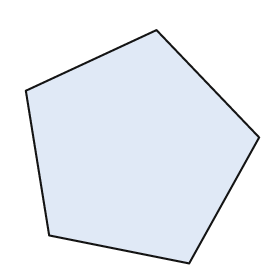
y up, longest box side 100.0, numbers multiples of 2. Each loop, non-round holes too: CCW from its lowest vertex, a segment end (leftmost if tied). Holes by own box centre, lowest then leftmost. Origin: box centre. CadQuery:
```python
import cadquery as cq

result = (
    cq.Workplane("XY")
    .moveTo(20.0, -50.0)
    .lineTo(50.0, 4.0)
    .lineTo(6.0, 50.0)
    .lineTo(-50.0, 24.0)
    .lineTo(-40.0, -38.0)
    .close()
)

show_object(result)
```